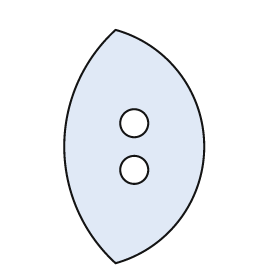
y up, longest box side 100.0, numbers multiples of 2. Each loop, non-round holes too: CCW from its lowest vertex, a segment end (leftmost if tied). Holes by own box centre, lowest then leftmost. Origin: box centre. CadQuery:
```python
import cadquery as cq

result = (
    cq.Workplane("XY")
    .moveTo(-8.0, -50.0)
    .threePointArc((30.0, 0.0), (-8.0, 50.0))
    .threePointArc((-30.0, 0.0), (-8.0, -50.0))
    .close()
    .moveTo(0.0, -10.0)
    .circle(6.0)
    .moveTo(0.0, 10.0)
    .circle(6.0)
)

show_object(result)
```